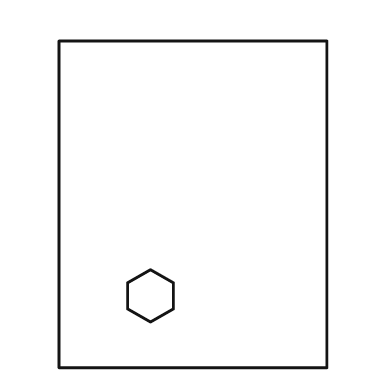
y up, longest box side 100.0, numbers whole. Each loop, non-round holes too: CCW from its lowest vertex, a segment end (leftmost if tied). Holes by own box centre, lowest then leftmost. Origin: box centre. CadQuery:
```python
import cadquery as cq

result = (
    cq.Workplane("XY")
    .moveTo(-41.0, -50.0)
    .lineTo(41.0, -50.0)
    .lineTo(41.0, 50.0)
    .lineTo(-41.0, 50.0)
    .close()
    .moveTo(-13.0, -36.0)
    .lineTo(-6.0, -32.0)
    .lineTo(-6.0, -24.0)
    .lineTo(-13.0, -20.0)
    .lineTo(-20.0, -24.0)
    .lineTo(-20.0, -32.0)
    .close()
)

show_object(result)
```